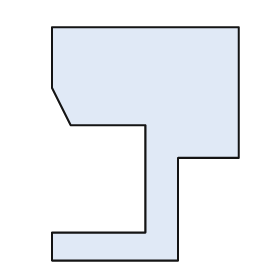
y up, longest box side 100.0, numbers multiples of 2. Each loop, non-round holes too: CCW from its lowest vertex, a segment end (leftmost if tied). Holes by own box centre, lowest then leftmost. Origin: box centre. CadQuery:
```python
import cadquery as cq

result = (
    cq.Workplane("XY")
    .moveTo(-40.0, -50.0)
    .lineTo(14.0, -50.0)
    .lineTo(14.0, -6.0)
    .lineTo(40.0, -6.0)
    .lineTo(40.0, 50.0)
    .lineTo(-40.0, 50.0)
    .lineTo(-40.0, 24.0)
    .lineTo(-32.0, 8.0)
    .lineTo(0.0, 8.0)
    .lineTo(0.0, -38.0)
    .lineTo(-40.0, -38.0)
    .close()
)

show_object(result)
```